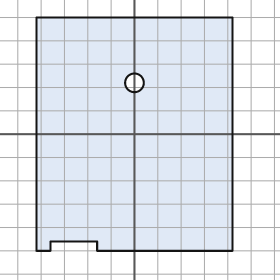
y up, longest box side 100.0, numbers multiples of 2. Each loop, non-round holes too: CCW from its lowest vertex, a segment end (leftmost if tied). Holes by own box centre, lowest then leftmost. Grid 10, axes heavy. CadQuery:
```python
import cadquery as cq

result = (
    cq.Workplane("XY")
    .moveTo(-42.0, -50.0)
    .lineTo(-36.0, -50.0)
    .lineTo(-36.0, -46.0)
    .lineTo(-16.0, -46.0)
    .lineTo(-16.0, -50.0)
    .lineTo(42.0, -50.0)
    .lineTo(42.0, 50.0)
    .lineTo(-42.0, 50.0)
    .close()
    .moveTo(0.0, 22.0)
    .circle(4.0)
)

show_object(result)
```